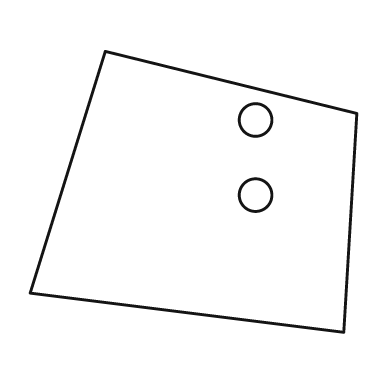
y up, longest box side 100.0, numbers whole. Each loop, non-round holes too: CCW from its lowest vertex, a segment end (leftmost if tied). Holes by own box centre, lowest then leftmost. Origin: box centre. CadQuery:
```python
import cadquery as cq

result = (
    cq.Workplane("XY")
    .moveTo(46.0, -43.0)
    .lineTo(50.0, 24.0)
    .lineTo(-27.0, 43.0)
    .lineTo(-50.0, -31.0)
    .close()
    .moveTo(19.0, -1.0)
    .circle(5.0)
    .moveTo(19.0, 22.0)
    .circle(5.0)
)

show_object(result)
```